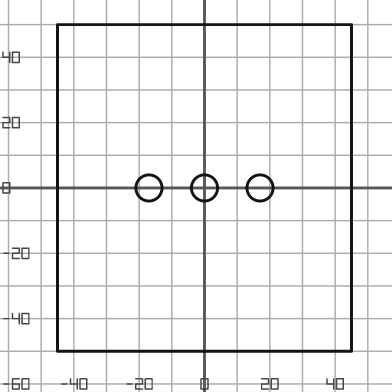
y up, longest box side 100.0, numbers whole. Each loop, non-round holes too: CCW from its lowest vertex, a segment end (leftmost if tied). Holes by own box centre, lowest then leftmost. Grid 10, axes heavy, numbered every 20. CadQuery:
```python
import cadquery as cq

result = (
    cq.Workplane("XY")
    .moveTo(-45.0, -50.0)
    .lineTo(45.0, -50.0)
    .lineTo(45.0, 50.0)
    .lineTo(-45.0, 50.0)
    .close()
    .moveTo(-17.0, 0.0)
    .circle(4.0)
    .moveTo(0.0, 0.0)
    .circle(4.0)
    .moveTo(17.0, 0.0)
    .circle(4.0)
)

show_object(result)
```